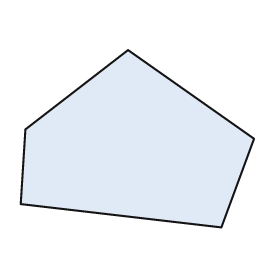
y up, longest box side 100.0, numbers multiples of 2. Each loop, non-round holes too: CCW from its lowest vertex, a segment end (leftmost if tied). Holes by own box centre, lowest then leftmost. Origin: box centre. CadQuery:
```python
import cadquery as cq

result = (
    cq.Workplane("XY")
    .moveTo(36.0, -38.0)
    .lineTo(50.0, 0.0)
    .lineTo(-4.0, 38.0)
    .lineTo(-48.0, 4.0)
    .lineTo(-50.0, -28.0)
    .close()
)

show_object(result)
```